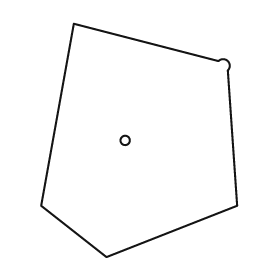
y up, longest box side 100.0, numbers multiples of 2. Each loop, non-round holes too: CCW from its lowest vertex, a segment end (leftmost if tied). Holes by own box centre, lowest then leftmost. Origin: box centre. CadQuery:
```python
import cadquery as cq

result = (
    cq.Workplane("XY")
    .moveTo(-14.0, -50.0)
    .lineTo(42.0, -28.0)
    .lineTo(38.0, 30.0)
    .threePointArc((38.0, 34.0), (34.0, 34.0))
    .lineTo(-28.0, 50.0)
    .lineTo(-42.0, -28.0)
    .close()
    .moveTo(-6.0, 0.0)
    .circle(2.0)
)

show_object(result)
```